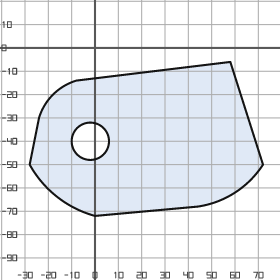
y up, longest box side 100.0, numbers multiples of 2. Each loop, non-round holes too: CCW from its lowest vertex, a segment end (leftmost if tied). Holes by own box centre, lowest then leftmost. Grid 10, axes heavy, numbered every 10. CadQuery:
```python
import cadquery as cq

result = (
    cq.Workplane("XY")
    .moveTo(0.0, -72.0)
    .lineTo(44.0, -68.0)
    .threePointArc((60.0, -62.0), (72.0, -50.0))
    .lineTo(58.0, -6.0)
    .lineTo(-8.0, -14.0)
    .threePointArc((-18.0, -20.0), (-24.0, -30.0))
    .lineTo(-28.0, -50.0)
    .threePointArc((-16.0, -64.0), (0.0, -72.0))
    .close()
    .moveTo(-2.0, -40.0)
    .circle(8.0)
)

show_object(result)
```